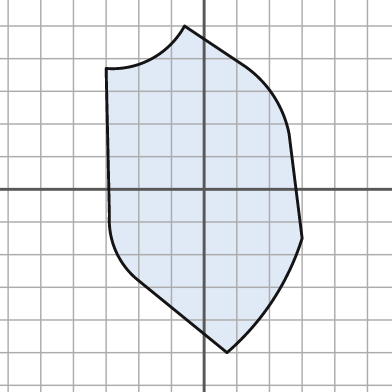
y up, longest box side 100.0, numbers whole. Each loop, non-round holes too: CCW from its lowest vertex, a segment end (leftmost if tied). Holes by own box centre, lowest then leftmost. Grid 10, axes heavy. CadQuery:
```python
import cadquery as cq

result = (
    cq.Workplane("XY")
    .moveTo(7.0, -50.0)
    .threePointArc((21.0, -34.0), (30.0, -15.0))
    .lineTo(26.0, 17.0)
    .threePointArc((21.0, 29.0), (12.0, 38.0))
    .lineTo(-6.0, 50.0)
    .threePointArc((-16.0, 40.0), (-30.0, 37.0))
    .lineTo(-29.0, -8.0)
    .threePointArc((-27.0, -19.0), (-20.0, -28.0))
    .close()
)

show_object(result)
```